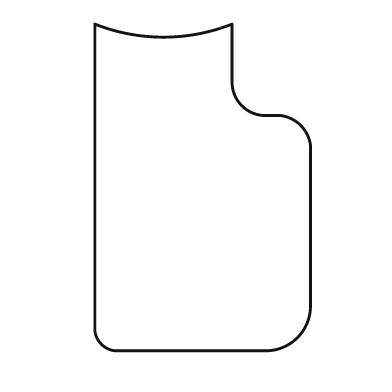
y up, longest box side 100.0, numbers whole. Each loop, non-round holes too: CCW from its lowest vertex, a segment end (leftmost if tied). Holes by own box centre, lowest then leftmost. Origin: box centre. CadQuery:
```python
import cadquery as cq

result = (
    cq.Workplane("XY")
    .moveTo(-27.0, -50.0)
    .lineTo(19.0, -50.0)
    .threePointArc((29.0, -46.0), (33.0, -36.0))
    .lineTo(33.0, 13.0)
    .threePointArc((30.0, 19.0), (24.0, 22.0))
    .lineTo(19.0, 22.0)
    .threePointArc((12.0, 25.0), (9.0, 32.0))
    .lineTo(9.0, 50.0)
    .threePointArc((-12.0, 46.0), (-33.0, 50.0))
    .lineTo(-33.0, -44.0)
    .threePointArc((-31.0, -48.0), (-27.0, -50.0))
    .close()
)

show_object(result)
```